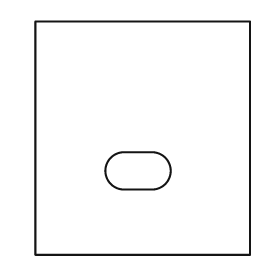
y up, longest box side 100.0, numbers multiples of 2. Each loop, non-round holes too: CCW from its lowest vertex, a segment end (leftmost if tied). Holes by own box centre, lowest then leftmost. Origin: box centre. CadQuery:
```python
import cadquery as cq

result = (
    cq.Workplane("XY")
    .moveTo(-46.0, -50.0)
    .lineTo(46.0, -50.0)
    .lineTo(46.0, 50.0)
    .lineTo(-46.0, 50.0)
    .close()
    .moveTo(-8.0, -22.0)
    .lineTo(4.0, -22.0)
    .threePointArc((12.0, -14.0), (4.0, -6.0))
    .lineTo(-8.0, -6.0)
    .threePointArc((-16.0, -14.0), (-8.0, -22.0))
    .close()
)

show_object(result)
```